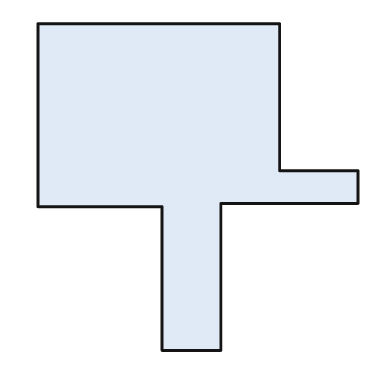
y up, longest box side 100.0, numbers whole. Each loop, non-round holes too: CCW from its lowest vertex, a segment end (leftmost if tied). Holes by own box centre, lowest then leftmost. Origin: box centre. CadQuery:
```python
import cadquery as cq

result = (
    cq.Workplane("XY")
    .moveTo(-11.0, -50.0)
    .lineTo(7.0, -50.0)
    .lineTo(7.0, -5.0)
    .lineTo(49.0, -5.0)
    .lineTo(49.0, 5.0)
    .lineTo(25.0, 5.0)
    .lineTo(25.0, 50.0)
    .lineTo(-49.0, 50.0)
    .lineTo(-49.0, -6.0)
    .lineTo(-11.0, -6.0)
    .close()
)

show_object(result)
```